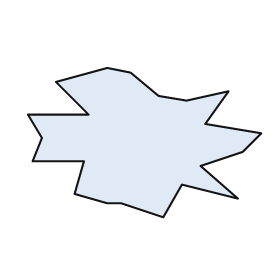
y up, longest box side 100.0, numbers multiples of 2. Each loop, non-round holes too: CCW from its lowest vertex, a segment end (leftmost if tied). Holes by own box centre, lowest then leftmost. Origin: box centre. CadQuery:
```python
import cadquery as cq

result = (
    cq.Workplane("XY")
    .moveTo(8.0, -32.0)
    .lineTo(16.0, -18.0)
    .lineTo(40.0, -24.0)
    .lineTo(24.0, -10.0)
    .lineTo(42.0, -4.0)
    .lineTo(50.0, 4.0)
    .lineTo(26.0, 8.0)
    .lineTo(36.0, 22.0)
    .lineTo(18.0, 18.0)
    .lineTo(6.0, 20.0)
    .lineTo(-6.0, 30.0)
    .lineTo(-16.0, 32.0)
    .lineTo(-38.0, 26.0)
    .lineTo(-24.0, 12.0)
    .lineTo(-50.0, 12.0)
    .lineTo(-44.0, 2.0)
    .lineTo(-48.0, -8.0)
    .lineTo(-26.0, -8.0)
    .lineTo(-30.0, -22.0)
    .lineTo(-16.0, -26.0)
    .lineTo(-10.0, -26.0)
    .close()
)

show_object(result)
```